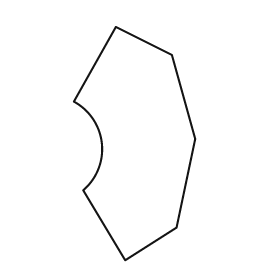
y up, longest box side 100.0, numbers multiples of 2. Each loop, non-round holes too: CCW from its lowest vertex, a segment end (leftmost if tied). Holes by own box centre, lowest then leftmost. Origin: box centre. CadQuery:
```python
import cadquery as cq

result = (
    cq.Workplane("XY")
    .moveTo(-4.0, -50.0)
    .lineTo(18.0, -36.0)
    .lineTo(26.0, 2.0)
    .lineTo(16.0, 38.0)
    .lineTo(-8.0, 50.0)
    .lineTo(-26.0, 18.0)
    .threePointArc((-14.0, 0.0), (-22.0, -20.0))
    .close()
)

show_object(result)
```